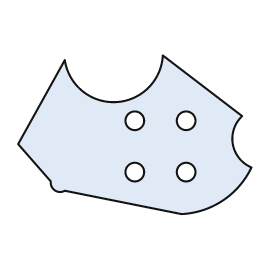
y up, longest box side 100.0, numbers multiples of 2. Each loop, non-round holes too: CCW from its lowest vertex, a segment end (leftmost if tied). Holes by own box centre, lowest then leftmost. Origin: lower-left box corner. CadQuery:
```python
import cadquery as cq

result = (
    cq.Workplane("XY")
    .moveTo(70.0, 0.0)
    .threePointArc((88.0, 6.0), (100.0, 20.0))
    .threePointArc((92.0, 30.0), (96.0, 42.0))
    .lineTo(62.0, 68.0)
    .threePointArc((42.0, 48.0), (20.0, 66.0))
    .lineTo(0.0, 30.0)
    .lineTo(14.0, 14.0)
    .threePointArc((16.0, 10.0), (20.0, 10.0))
    .close()
    .moveTo(50.0, 18.0)
    .circle(4.0)
    .moveTo(72.0, 18.0)
    .circle(4.0)
    .moveTo(50.0, 40.0)
    .circle(4.0)
    .moveTo(72.0, 40.0)
    .circle(4.0)
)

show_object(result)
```